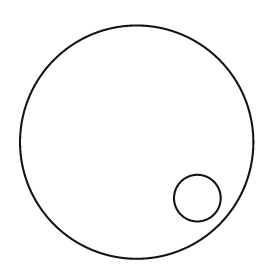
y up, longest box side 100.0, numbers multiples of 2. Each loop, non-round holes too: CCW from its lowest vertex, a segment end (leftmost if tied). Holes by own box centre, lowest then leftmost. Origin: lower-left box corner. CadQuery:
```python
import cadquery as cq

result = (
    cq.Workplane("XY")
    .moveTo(50.0, 50.0)
    .circle(50.0)
    .moveTo(76.0, 26.0)
    .circle(10.0)
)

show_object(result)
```